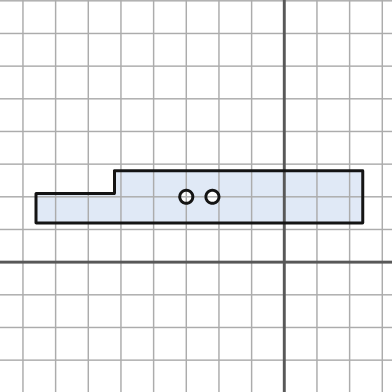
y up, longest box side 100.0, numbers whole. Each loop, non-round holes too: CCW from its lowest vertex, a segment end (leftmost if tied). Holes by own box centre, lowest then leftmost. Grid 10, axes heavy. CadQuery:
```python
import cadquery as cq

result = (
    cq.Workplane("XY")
    .moveTo(-76.0, 12.0)
    .lineTo(24.0, 12.0)
    .lineTo(24.0, 28.0)
    .lineTo(-52.0, 28.0)
    .lineTo(-52.0, 21.0)
    .lineTo(-76.0, 21.0)
    .close()
    .moveTo(-30.0, 20.0)
    .circle(2.0)
    .moveTo(-22.0, 20.0)
    .circle(2.0)
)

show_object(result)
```